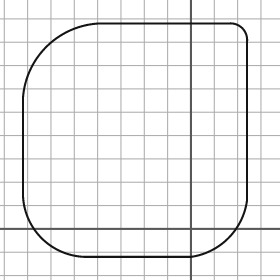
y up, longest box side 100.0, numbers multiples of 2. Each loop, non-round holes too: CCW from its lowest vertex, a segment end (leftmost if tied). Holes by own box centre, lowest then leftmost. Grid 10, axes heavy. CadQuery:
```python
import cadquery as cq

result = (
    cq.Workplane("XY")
    .moveTo(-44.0, -12.0)
    .lineTo(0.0, -12.0)
    .threePointArc((16.0, -4.0), (24.0, 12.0))
    .lineTo(24.0, 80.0)
    .threePointArc((22.0, 86.0), (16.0, 88.0))
    .lineTo(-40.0, 88.0)
    .threePointArc((-62.0, 78.0), (-72.0, 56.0))
    .lineTo(-72.0, 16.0)
    .threePointArc((-64.0, -4.0), (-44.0, -12.0))
    .close()
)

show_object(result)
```